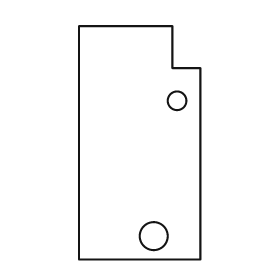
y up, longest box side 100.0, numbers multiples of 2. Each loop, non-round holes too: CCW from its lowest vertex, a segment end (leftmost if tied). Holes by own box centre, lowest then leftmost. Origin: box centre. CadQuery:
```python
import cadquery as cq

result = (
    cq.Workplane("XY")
    .moveTo(-26.0, -50.0)
    .lineTo(26.0, -50.0)
    .lineTo(26.0, 32.0)
    .lineTo(14.0, 32.0)
    .lineTo(14.0, 50.0)
    .lineTo(-26.0, 50.0)
    .close()
    .moveTo(6.0, -40.0)
    .circle(6.0)
    .moveTo(16.0, 18.0)
    .circle(4.0)
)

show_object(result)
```